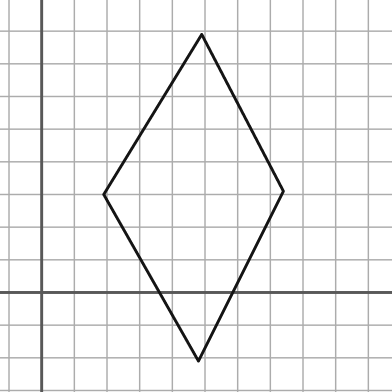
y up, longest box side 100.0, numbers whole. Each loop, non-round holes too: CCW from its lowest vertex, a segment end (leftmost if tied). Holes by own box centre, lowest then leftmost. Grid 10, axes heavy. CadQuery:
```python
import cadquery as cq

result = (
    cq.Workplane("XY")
    .moveTo(48.0, -21.0)
    .lineTo(74.0, 31.0)
    .lineTo(49.0, 79.0)
    .lineTo(19.0, 30.0)
    .close()
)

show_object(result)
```